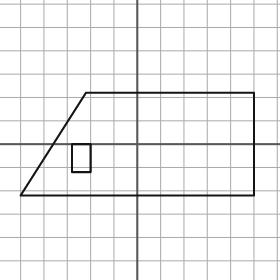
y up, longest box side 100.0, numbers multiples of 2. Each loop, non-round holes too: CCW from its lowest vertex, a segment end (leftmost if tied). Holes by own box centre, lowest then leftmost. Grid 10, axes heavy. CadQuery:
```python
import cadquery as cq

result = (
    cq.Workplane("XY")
    .moveTo(-50.0, -22.0)
    .lineTo(50.0, -22.0)
    .lineTo(50.0, 22.0)
    .lineTo(-22.0, 22.0)
    .close()
    .moveTo(-28.0, -12.0)
    .lineTo(-20.0, -12.0)
    .lineTo(-20.0, 0.0)
    .lineTo(-28.0, 0.0)
    .close()
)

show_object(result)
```